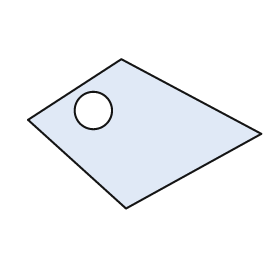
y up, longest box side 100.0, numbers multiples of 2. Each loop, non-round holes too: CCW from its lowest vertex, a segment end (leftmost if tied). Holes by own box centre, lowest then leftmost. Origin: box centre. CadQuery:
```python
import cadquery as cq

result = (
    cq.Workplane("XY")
    .moveTo(-8.0, -32.0)
    .lineTo(50.0, 0.0)
    .lineTo(-10.0, 32.0)
    .lineTo(-50.0, 6.0)
    .close()
    .moveTo(-22.0, 10.0)
    .circle(8.0)
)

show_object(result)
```